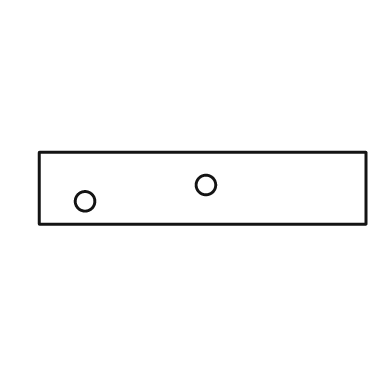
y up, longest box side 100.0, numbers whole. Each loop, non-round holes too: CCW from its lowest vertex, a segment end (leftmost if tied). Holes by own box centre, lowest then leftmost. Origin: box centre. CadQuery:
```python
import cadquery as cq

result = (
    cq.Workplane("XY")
    .moveTo(-50.0, -11.0)
    .lineTo(50.0, -11.0)
    .lineTo(50.0, 11.0)
    .lineTo(-50.0, 11.0)
    .close()
    .moveTo(-36.0, -4.0)
    .circle(3.0)
    .moveTo(1.0, 1.0)
    .circle(3.0)
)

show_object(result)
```